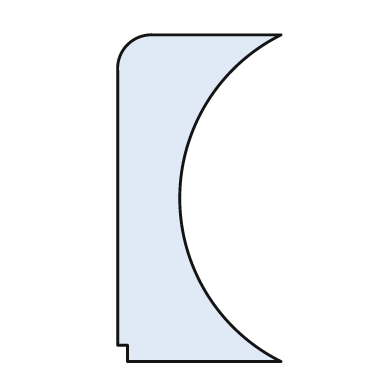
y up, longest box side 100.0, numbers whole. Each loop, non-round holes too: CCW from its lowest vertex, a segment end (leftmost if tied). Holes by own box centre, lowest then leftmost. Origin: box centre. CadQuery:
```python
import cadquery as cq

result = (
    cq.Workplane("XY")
    .moveTo(-22.0, -50.0)
    .lineTo(25.0, -50.0)
    .threePointArc((-6.0, 0.0), (25.0, 50.0))
    .lineTo(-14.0, 50.0)
    .threePointArc((-22.0, 47.0), (-25.0, 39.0))
    .lineTo(-25.0, -45.0)
    .lineTo(-22.0, -45.0)
    .close()
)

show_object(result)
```